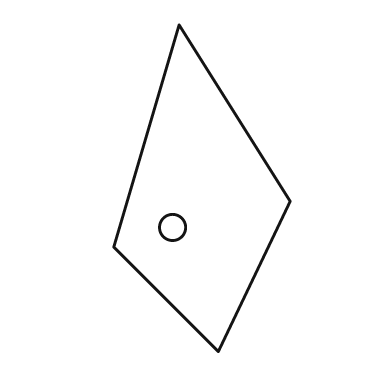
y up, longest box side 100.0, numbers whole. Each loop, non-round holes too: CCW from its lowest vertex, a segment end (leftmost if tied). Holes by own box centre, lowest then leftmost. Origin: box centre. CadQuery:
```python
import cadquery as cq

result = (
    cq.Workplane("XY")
    .moveTo(5.0, -50.0)
    .lineTo(27.0, -4.0)
    .lineTo(-7.0, 50.0)
    .lineTo(-27.0, -18.0)
    .close()
    .moveTo(-9.0, -12.0)
    .circle(4.0)
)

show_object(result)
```